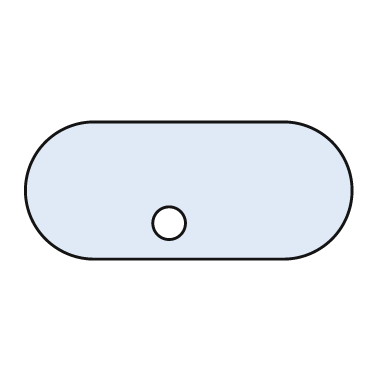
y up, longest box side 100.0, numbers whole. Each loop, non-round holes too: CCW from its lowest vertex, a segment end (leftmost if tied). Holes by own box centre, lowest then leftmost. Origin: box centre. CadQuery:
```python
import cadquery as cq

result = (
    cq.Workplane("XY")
    .moveTo(-29.0, -21.0)
    .lineTo(29.0, -21.0)
    .threePointArc((50.0, 0.0), (29.0, 21.0))
    .lineTo(-29.0, 21.0)
    .threePointArc((-50.0, 0.0), (-29.0, -21.0))
    .close()
    .moveTo(-6.0, -10.0)
    .circle(5.0)
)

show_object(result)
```